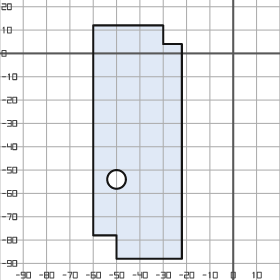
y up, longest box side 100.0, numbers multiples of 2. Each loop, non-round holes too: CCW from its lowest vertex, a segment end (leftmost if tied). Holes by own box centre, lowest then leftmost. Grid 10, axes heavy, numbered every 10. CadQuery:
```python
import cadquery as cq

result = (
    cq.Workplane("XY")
    .moveTo(-50.0, -88.0)
    .lineTo(-22.0, -88.0)
    .lineTo(-22.0, 4.0)
    .lineTo(-30.0, 4.0)
    .lineTo(-30.0, 12.0)
    .lineTo(-60.0, 12.0)
    .lineTo(-60.0, -78.0)
    .lineTo(-50.0, -78.0)
    .close()
    .moveTo(-50.0, -54.0)
    .circle(4.0)
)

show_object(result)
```